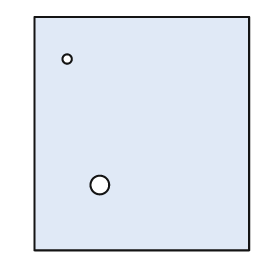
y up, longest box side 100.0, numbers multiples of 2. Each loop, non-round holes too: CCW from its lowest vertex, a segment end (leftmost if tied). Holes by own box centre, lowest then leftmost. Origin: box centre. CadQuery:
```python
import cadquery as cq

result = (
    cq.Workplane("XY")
    .moveTo(-46.0, -50.0)
    .lineTo(46.0, -50.0)
    .lineTo(46.0, 50.0)
    .lineTo(-46.0, 50.0)
    .close()
    .moveTo(-18.0, -22.0)
    .circle(4.0)
    .moveTo(-32.0, 32.0)
    .circle(2.0)
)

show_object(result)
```